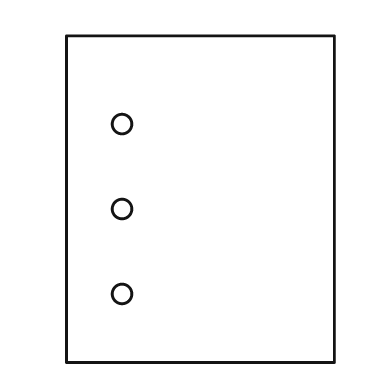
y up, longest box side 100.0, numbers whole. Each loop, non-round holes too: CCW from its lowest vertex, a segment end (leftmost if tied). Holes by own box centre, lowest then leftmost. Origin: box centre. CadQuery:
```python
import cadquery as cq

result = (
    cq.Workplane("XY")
    .moveTo(-41.0, -50.0)
    .lineTo(41.0, -50.0)
    .lineTo(41.0, 50.0)
    .lineTo(-41.0, 50.0)
    .close()
    .moveTo(-24.0, -29.0)
    .circle(3.0)
    .moveTo(-24.0, -3.0)
    .circle(3.0)
    .moveTo(-24.0, 23.0)
    .circle(3.0)
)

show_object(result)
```